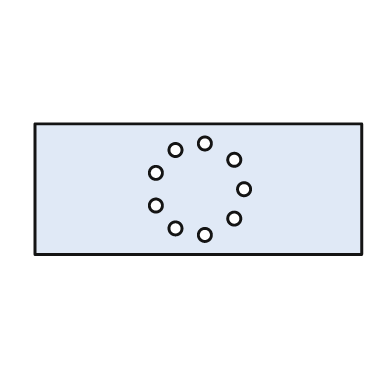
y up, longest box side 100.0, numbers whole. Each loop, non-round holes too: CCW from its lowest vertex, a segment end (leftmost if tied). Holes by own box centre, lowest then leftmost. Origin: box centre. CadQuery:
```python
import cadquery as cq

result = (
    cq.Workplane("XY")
    .moveTo(-50.0, -20.0)
    .lineTo(50.0, -20.0)
    .lineTo(50.0, 20.0)
    .lineTo(-50.0, 20.0)
    .close()
    .moveTo(2.0, -14.0)
    .circle(2.0)
    .moveTo(-7.0, -12.0)
    .circle(2.0)
    .moveTo(11.0, -9.0)
    .circle(2.0)
    .moveTo(-13.0, -5.0)
    .circle(2.0)
    .moveTo(14.0, 0.0)
    .circle(2.0)
    .moveTo(-13.0, 5.0)
    .circle(2.0)
    .moveTo(11.0, 9.0)
    .circle(2.0)
    .moveTo(-7.0, 12.0)
    .circle(2.0)
    .moveTo(2.0, 14.0)
    .circle(2.0)
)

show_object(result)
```